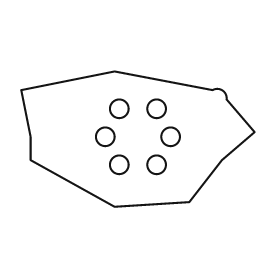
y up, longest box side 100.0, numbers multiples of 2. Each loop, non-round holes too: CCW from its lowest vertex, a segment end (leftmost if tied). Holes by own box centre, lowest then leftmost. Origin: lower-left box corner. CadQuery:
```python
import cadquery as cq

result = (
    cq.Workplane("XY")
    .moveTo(40.0, 0.0)
    .lineTo(72.0, 2.0)
    .lineTo(86.0, 20.0)
    .lineTo(100.0, 32.0)
    .lineTo(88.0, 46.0)
    .threePointArc((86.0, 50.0), (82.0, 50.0))
    .lineTo(40.0, 58.0)
    .lineTo(0.0, 50.0)
    .lineTo(4.0, 30.0)
    .lineTo(4.0, 20.0)
    .close()
    .moveTo(42.0, 18.0)
    .circle(4.0)
    .moveTo(58.0, 18.0)
    .circle(4.0)
    .moveTo(36.0, 30.0)
    .circle(4.0)
    .moveTo(64.0, 30.0)
    .circle(4.0)
    .moveTo(42.0, 42.0)
    .circle(4.0)
    .moveTo(58.0, 42.0)
    .circle(4.0)
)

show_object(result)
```